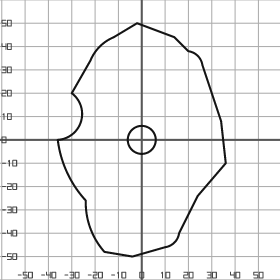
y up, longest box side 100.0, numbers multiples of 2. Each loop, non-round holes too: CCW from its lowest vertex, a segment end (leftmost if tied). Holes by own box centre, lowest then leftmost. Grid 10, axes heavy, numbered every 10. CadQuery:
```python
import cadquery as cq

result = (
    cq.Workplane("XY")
    .moveTo(-4.0, -50.0)
    .lineTo(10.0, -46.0)
    .threePointArc((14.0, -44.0), (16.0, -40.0))
    .lineTo(24.0, -24.0)
    .lineTo(36.0, -10.0)
    .lineTo(34.0, 8.0)
    .lineTo(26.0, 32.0)
    .threePointArc((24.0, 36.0), (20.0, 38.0))
    .lineTo(14.0, 44.0)
    .lineTo(-2.0, 50.0)
    .lineTo(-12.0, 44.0)
    .threePointArc((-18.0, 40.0), (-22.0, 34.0))
    .lineTo(-30.0, 20.0)
    .threePointArc((-26.0, 8.0), (-36.0, 0.0))
    .threePointArc((-32.0, -14.0), (-24.0, -26.0))
    .threePointArc((-22.0, -38.0), (-16.0, -48.0))
    .close()
    .moveTo(0.0, 0.0)
    .circle(6.0)
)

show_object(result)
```